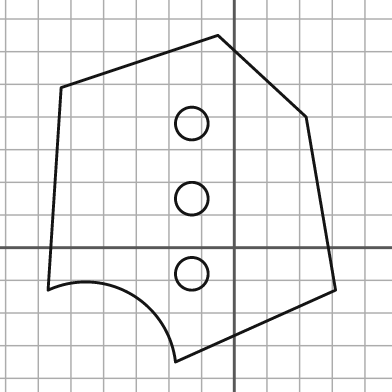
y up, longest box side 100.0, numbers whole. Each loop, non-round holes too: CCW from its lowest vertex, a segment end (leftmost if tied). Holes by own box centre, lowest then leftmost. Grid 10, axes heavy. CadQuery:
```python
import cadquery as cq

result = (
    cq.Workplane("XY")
    .moveTo(-18.0, -35.0)
    .lineTo(31.0, -13.0)
    .lineTo(22.0, 40.0)
    .lineTo(-5.0, 65.0)
    .lineTo(-53.0, 49.0)
    .lineTo(-57.0, -13.0)
    .threePointArc((-32.0, -14.0), (-18.0, -35.0))
    .close()
    .moveTo(-13.0, -8.0)
    .circle(5.0)
    .moveTo(-13.0, 15.0)
    .circle(5.0)
    .moveTo(-13.0, 38.0)
    .circle(5.0)
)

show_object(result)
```